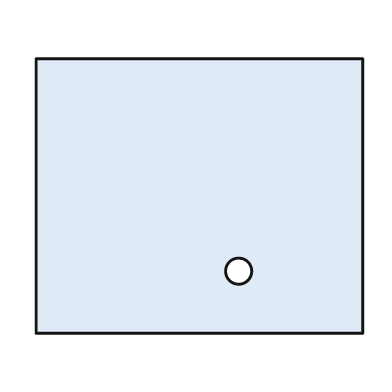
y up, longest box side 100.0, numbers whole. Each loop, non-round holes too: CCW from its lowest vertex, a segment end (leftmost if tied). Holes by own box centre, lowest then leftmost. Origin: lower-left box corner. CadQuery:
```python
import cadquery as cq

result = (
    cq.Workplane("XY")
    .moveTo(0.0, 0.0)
    .lineTo(100.0, 0.0)
    .lineTo(100.0, 84.0)
    .lineTo(0.0, 84.0)
    .close()
    .moveTo(62.0, 19.0)
    .circle(4.0)
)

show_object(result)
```